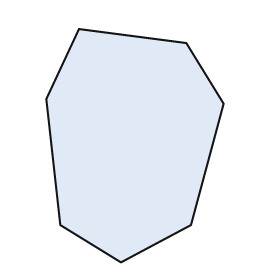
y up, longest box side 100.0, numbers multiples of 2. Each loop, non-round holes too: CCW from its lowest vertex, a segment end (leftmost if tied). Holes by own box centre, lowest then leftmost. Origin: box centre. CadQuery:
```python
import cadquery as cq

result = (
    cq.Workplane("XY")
    .moveTo(-6.0, -50.0)
    .lineTo(24.0, -34.0)
    .lineTo(38.0, 18.0)
    .lineTo(22.0, 44.0)
    .lineTo(-24.0, 50.0)
    .lineTo(-38.0, 20.0)
    .lineTo(-32.0, -34.0)
    .close()
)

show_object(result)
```